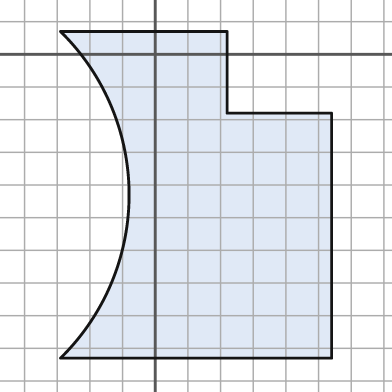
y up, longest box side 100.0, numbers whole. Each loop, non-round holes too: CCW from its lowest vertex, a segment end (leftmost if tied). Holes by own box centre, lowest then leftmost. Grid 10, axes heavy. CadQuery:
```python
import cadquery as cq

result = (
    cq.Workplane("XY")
    .moveTo(-29.0, -93.0)
    .lineTo(54.0, -93.0)
    .lineTo(54.0, -18.0)
    .lineTo(22.0, -18.0)
    .lineTo(22.0, 7.0)
    .lineTo(-29.0, 7.0)
    .threePointArc((-8.0, -43.0), (-29.0, -93.0))
    .close()
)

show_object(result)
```